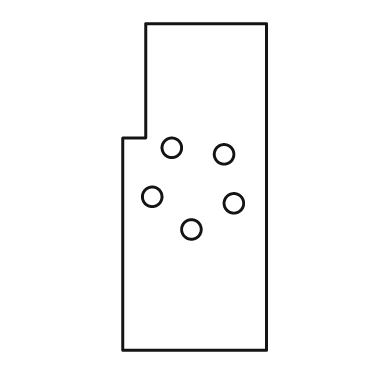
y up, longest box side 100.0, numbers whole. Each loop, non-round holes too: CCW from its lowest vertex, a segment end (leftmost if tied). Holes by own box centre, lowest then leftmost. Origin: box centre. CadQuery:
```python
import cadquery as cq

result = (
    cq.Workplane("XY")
    .moveTo(-22.0, -50.0)
    .lineTo(22.0, -50.0)
    .lineTo(22.0, 50.0)
    .lineTo(-15.0, 50.0)
    .lineTo(-15.0, 15.0)
    .lineTo(-22.0, 15.0)
    .close()
    .moveTo(-1.0, -13.0)
    .circle(3.0)
    .moveTo(12.0, -5.0)
    .circle(3.0)
    .moveTo(-13.0, -3.0)
    .circle(3.0)
    .moveTo(9.0, 10.0)
    .circle(3.0)
    .moveTo(-7.0, 12.0)
    .circle(3.0)
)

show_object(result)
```